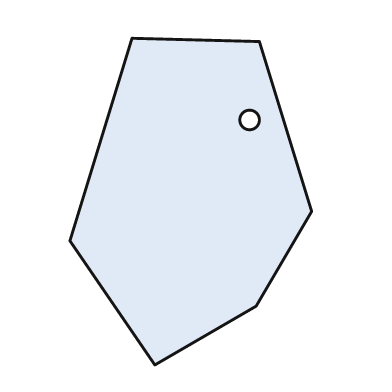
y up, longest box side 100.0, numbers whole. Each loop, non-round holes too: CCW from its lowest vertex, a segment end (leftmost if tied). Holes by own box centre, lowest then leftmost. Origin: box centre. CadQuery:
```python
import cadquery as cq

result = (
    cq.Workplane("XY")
    .moveTo(-11.0, -50.0)
    .lineTo(20.0, -32.0)
    .lineTo(37.0, -3.0)
    .lineTo(21.0, 49.0)
    .lineTo(-18.0, 50.0)
    .lineTo(-37.0, -12.0)
    .close()
    .moveTo(18.0, 25.0)
    .circle(3.0)
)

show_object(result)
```